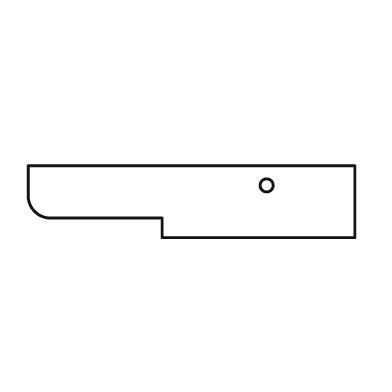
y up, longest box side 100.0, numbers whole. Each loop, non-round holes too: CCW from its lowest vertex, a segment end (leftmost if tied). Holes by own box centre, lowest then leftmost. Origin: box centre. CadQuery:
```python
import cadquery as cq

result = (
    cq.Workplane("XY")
    .moveTo(-9.0, -11.0)
    .lineTo(50.0, -11.0)
    .lineTo(50.0, 11.0)
    .lineTo(-50.0, 11.0)
    .lineTo(-50.0, 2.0)
    .threePointArc((-48.0, -3.0), (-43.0, -5.0))
    .lineTo(-9.0, -5.0)
    .close()
    .moveTo(23.0, 5.0)
    .circle(2.0)
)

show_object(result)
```